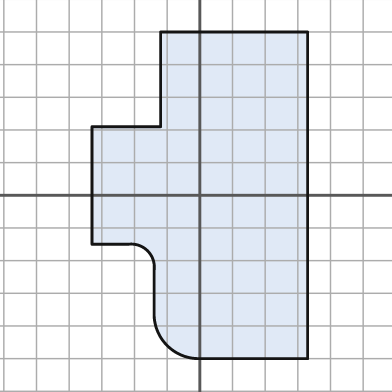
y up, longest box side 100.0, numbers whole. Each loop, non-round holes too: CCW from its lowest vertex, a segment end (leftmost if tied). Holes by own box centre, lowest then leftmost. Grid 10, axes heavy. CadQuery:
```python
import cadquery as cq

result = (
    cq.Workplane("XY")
    .moveTo(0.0, -50.0)
    .lineTo(33.0, -50.0)
    .lineTo(33.0, 50.0)
    .lineTo(-12.0, 50.0)
    .lineTo(-12.0, 21.0)
    .lineTo(-33.0, 21.0)
    .lineTo(-33.0, -15.0)
    .lineTo(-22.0, -15.0)
    .threePointArc((-16.0, -17.0), (-14.0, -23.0))
    .lineTo(-14.0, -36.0)
    .threePointArc((-10.0, -46.0), (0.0, -50.0))
    .close()
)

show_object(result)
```